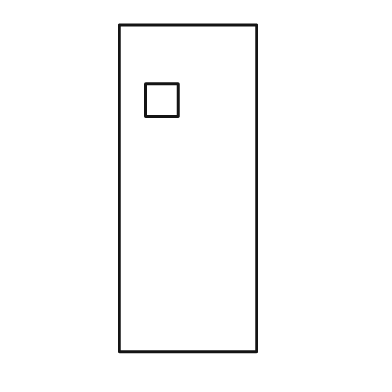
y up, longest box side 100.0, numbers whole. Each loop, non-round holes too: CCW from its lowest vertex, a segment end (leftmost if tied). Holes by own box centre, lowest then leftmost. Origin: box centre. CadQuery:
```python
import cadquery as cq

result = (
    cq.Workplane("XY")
    .moveTo(-21.0, -50.0)
    .lineTo(21.0, -50.0)
    .lineTo(21.0, 50.0)
    .lineTo(-21.0, 50.0)
    .close()
    .moveTo(-13.0, 22.0)
    .lineTo(-3.0, 22.0)
    .lineTo(-3.0, 32.0)
    .lineTo(-13.0, 32.0)
    .close()
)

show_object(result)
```